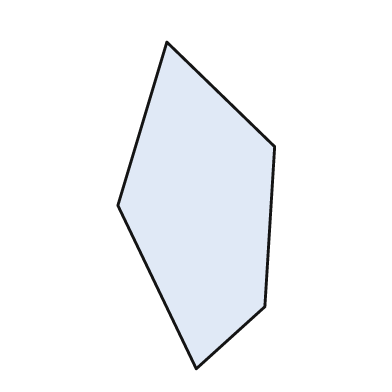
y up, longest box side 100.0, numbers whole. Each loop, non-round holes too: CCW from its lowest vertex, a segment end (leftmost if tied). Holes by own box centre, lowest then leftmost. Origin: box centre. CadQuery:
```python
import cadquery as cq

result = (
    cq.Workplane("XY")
    .moveTo(0.0, -50.0)
    .lineTo(21.0, -31.0)
    .lineTo(24.0, 18.0)
    .lineTo(-9.0, 50.0)
    .lineTo(-24.0, 0.0)
    .close()
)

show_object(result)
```